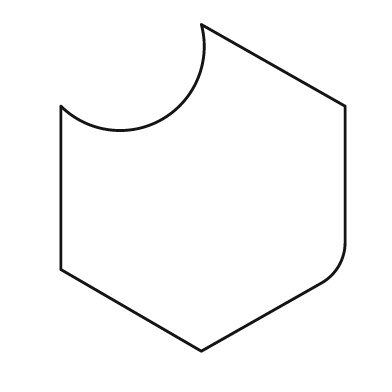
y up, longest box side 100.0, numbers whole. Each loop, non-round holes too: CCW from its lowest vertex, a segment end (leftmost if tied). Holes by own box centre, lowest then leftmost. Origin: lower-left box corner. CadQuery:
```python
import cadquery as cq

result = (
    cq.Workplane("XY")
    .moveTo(43.0, 0.0)
    .lineTo(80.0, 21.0)
    .threePointArc((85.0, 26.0), (87.0, 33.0))
    .lineTo(87.0, 75.0)
    .lineTo(43.0, 100.0)
    .threePointArc((31.0, 71.0), (0.0, 75.0))
    .lineTo(0.0, 25.0)
    .close()
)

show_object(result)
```